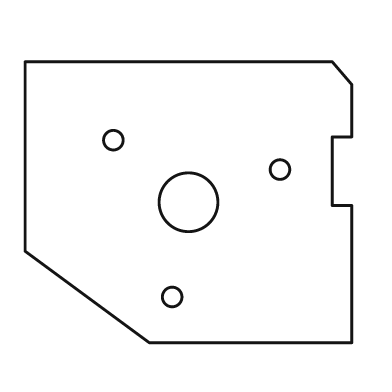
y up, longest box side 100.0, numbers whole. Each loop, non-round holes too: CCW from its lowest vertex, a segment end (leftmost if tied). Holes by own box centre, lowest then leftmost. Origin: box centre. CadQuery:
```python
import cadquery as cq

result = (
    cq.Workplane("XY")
    .moveTo(-12.0, -43.0)
    .lineTo(50.0, -43.0)
    .lineTo(50.0, -1.0)
    .lineTo(44.0, -1.0)
    .lineTo(44.0, 20.0)
    .lineTo(50.0, 20.0)
    .lineTo(50.0, 36.0)
    .lineTo(44.0, 43.0)
    .lineTo(-50.0, 43.0)
    .lineTo(-50.0, -15.0)
    .close()
    .moveTo(-5.0, -29.0)
    .circle(3.0)
    .moveTo(0.0, 0.0)
    .circle(9.0)
    .moveTo(28.0, 10.0)
    .circle(3.0)
    .moveTo(-23.0, 19.0)
    .circle(3.0)
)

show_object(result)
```